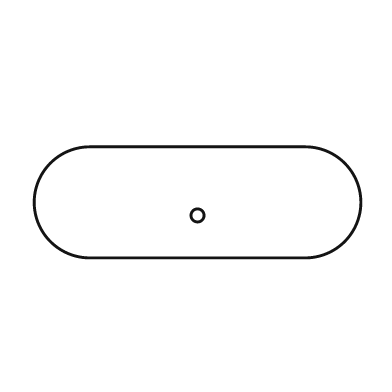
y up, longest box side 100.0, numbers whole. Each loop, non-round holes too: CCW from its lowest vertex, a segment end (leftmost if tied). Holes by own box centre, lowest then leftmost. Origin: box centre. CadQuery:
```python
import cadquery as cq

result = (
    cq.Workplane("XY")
    .moveTo(-33.0, -17.0)
    .lineTo(33.0, -17.0)
    .threePointArc((50.0, 0.0), (33.0, 17.0))
    .lineTo(-33.0, 17.0)
    .threePointArc((-50.0, 0.0), (-33.0, -17.0))
    .close()
    .moveTo(0.0, -4.0)
    .circle(2.0)
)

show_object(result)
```